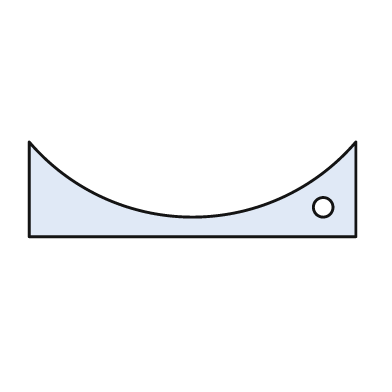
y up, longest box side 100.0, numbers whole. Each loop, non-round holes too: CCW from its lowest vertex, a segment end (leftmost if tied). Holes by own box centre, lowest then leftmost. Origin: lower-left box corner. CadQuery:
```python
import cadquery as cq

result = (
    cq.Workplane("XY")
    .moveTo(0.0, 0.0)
    .lineTo(100.0, 0.0)
    .lineTo(100.0, 29.0)
    .threePointArc((50.0, 6.0), (0.0, 29.0))
    .close()
    .moveTo(90.0, 9.0)
    .circle(3.0)
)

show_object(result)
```